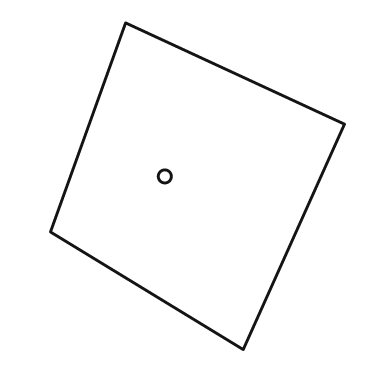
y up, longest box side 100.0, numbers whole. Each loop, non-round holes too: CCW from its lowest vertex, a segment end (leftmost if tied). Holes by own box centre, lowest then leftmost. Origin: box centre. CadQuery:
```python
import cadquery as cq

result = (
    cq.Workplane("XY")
    .moveTo(14.0, -50.0)
    .lineTo(45.0, 19.0)
    .lineTo(-22.0, 50.0)
    .lineTo(-45.0, -14.0)
    .close()
    .moveTo(-10.0, 3.0)
    .circle(2.0)
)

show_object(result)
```